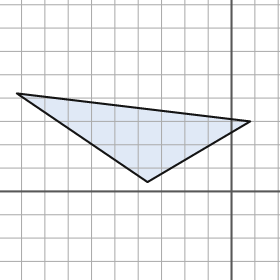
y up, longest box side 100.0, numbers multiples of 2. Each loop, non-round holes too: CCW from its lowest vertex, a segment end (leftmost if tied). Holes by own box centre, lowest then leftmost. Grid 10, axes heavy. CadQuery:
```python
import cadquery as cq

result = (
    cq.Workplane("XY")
    .moveTo(-36.0, 4.0)
    .lineTo(8.0, 30.0)
    .lineTo(-92.0, 42.0)
    .close()
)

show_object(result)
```